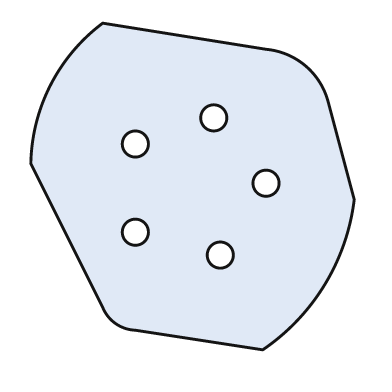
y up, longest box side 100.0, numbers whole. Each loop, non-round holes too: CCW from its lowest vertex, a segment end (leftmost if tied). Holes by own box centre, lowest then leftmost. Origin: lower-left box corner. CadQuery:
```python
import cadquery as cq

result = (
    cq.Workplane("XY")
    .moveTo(71.0, 0.0)
    .threePointArc((90.0, 20.0), (99.0, 46.0))
    .lineTo(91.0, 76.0)
    .threePointArc((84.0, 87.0), (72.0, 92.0))
    .lineTo(22.0, 100.0)
    .threePointArc((6.0, 81.0), (0.0, 57.0))
    .lineTo(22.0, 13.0)
    .threePointArc((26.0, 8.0), (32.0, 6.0))
    .close()
    .moveTo(58.0, 29.0)
    .circle(4.0)
    .moveTo(32.0, 36.0)
    .circle(4.0)
    .moveTo(72.0, 51.0)
    .circle(4.0)
    .moveTo(32.0, 63.0)
    .circle(4.0)
    .moveTo(56.0, 71.0)
    .circle(4.0)
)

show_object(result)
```